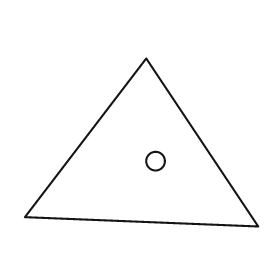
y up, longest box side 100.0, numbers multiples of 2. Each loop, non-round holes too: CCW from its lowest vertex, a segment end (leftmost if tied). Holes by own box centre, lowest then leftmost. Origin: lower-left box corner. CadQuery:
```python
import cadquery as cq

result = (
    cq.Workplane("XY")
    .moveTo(100.0, 0.0)
    .lineTo(52.0, 72.0)
    .lineTo(0.0, 4.0)
    .close()
    .moveTo(56.0, 28.0)
    .circle(4.0)
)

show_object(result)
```